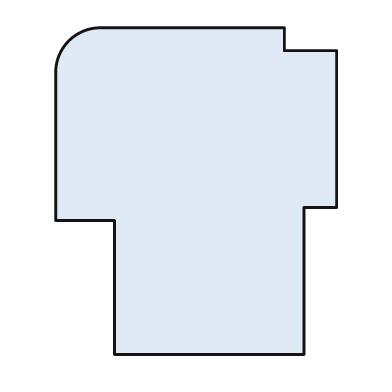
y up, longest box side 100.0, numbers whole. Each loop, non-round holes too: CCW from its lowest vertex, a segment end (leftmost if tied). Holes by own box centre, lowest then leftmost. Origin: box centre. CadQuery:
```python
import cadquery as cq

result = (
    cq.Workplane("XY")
    .moveTo(-25.0, -50.0)
    .lineTo(33.0, -50.0)
    .lineTo(33.0, -5.0)
    .lineTo(43.0, -5.0)
    .lineTo(43.0, 43.0)
    .lineTo(27.0, 43.0)
    .lineTo(27.0, 50.0)
    .lineTo(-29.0, 50.0)
    .threePointArc((-39.0, 46.0), (-43.0, 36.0))
    .lineTo(-43.0, -9.0)
    .lineTo(-25.0, -9.0)
    .close()
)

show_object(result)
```